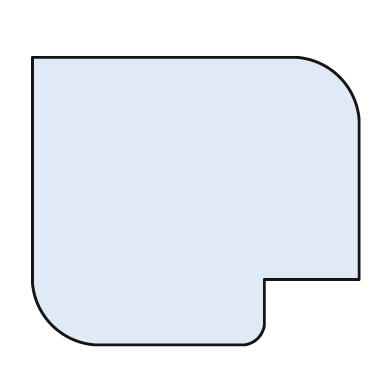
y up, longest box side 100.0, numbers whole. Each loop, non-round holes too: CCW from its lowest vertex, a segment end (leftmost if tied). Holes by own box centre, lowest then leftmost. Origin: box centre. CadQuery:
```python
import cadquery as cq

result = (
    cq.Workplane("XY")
    .moveTo(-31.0, -44.0)
    .lineTo(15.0, -44.0)
    .threePointArc((19.0, -42.0), (21.0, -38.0))
    .lineTo(21.0, -24.0)
    .lineTo(50.0, -24.0)
    .lineTo(50.0, 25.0)
    .threePointArc((44.0, 38.0), (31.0, 44.0))
    .lineTo(-50.0, 44.0)
    .lineTo(-50.0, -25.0)
    .threePointArc((-44.0, -38.0), (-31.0, -44.0))
    .close()
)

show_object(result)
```